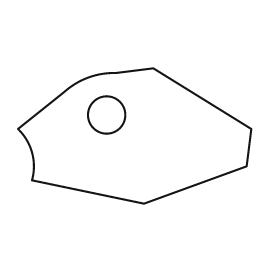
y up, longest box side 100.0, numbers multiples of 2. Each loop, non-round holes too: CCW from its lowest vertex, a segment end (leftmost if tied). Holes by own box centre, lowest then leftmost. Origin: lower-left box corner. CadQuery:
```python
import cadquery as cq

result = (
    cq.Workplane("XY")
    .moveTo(54.0, 0.0)
    .lineTo(98.0, 16.0)
    .lineTo(100.0, 32.0)
    .lineTo(58.0, 58.0)
    .lineTo(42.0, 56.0)
    .threePointArc((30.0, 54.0), (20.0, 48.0))
    .lineTo(0.0, 32.0)
    .threePointArc((6.0, 22.0), (6.0, 10.0))
    .close()
    .moveTo(38.0, 38.0)
    .circle(8.0)
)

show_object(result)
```